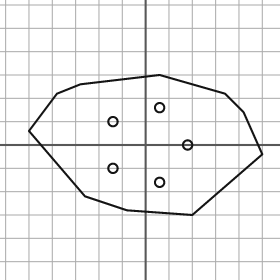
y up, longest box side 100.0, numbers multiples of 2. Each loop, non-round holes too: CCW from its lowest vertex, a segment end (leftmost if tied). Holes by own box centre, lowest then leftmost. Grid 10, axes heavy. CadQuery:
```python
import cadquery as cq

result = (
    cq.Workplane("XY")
    .moveTo(20.0, -30.0)
    .lineTo(50.0, -4.0)
    .lineTo(42.0, 14.0)
    .lineTo(34.0, 22.0)
    .lineTo(6.0, 30.0)
    .lineTo(-28.0, 26.0)
    .lineTo(-38.0, 22.0)
    .lineTo(-50.0, 6.0)
    .lineTo(-26.0, -22.0)
    .lineTo(-8.0, -28.0)
    .close()
    .moveTo(6.0, -16.0)
    .circle(2.0)
    .moveTo(-14.0, -10.0)
    .circle(2.0)
    .moveTo(18.0, 0.0)
    .circle(2.0)
    .moveTo(-14.0, 10.0)
    .circle(2.0)
    .moveTo(6.0, 16.0)
    .circle(2.0)
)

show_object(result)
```